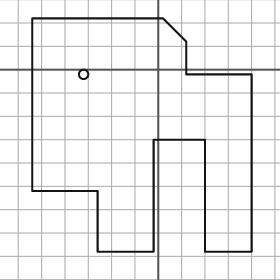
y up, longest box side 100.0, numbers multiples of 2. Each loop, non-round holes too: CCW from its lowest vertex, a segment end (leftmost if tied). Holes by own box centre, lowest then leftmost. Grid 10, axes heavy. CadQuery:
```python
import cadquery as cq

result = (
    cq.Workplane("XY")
    .moveTo(-26.0, -78.0)
    .lineTo(-2.0, -78.0)
    .lineTo(-2.0, -30.0)
    .lineTo(20.0, -30.0)
    .lineTo(20.0, -78.0)
    .lineTo(40.0, -78.0)
    .lineTo(40.0, -2.0)
    .lineTo(12.0, -2.0)
    .lineTo(12.0, 12.0)
    .lineTo(2.0, 22.0)
    .lineTo(-54.0, 22.0)
    .lineTo(-54.0, -52.0)
    .lineTo(-26.0, -52.0)
    .close()
    .moveTo(-32.0, -2.0)
    .circle(2.0)
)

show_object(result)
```